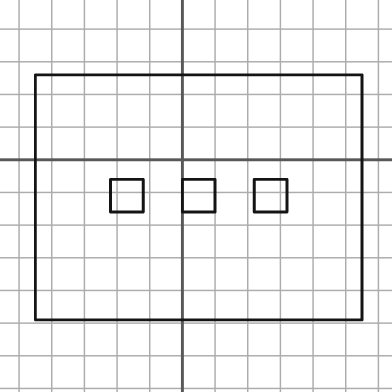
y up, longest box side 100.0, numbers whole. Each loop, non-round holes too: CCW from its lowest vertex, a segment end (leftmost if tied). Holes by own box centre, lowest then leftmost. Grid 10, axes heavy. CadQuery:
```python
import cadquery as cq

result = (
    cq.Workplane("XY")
    .moveTo(-45.0, -49.0)
    .lineTo(55.0, -49.0)
    .lineTo(55.0, 26.0)
    .lineTo(-45.0, 26.0)
    .close()
    .moveTo(-22.0, -16.0)
    .lineTo(-12.0, -16.0)
    .lineTo(-12.0, -6.0)
    .lineTo(-22.0, -6.0)
    .close()
    .moveTo(0.0, -16.0)
    .lineTo(10.0, -16.0)
    .lineTo(10.0, -6.0)
    .lineTo(0.0, -6.0)
    .close()
    .moveTo(22.0, -16.0)
    .lineTo(32.0, -16.0)
    .lineTo(32.0, -6.0)
    .lineTo(22.0, -6.0)
    .close()
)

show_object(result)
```